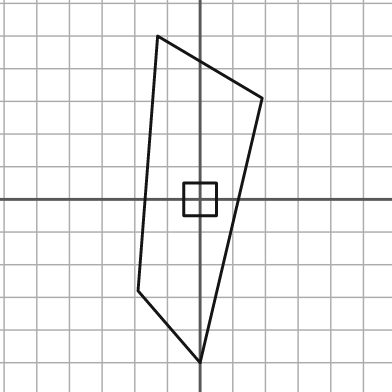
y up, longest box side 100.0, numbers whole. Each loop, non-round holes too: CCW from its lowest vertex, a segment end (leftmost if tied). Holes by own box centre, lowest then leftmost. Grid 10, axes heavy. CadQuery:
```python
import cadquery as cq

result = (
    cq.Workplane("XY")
    .moveTo(0.0, -50.0)
    .lineTo(19.0, 31.0)
    .lineTo(-13.0, 50.0)
    .lineTo(-19.0, -28.0)
    .close()
    .moveTo(-5.0, -5.0)
    .lineTo(5.0, -5.0)
    .lineTo(5.0, 5.0)
    .lineTo(-5.0, 5.0)
    .close()
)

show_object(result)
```